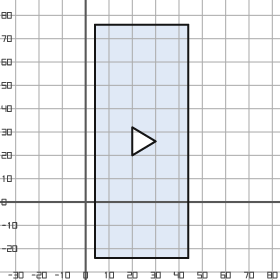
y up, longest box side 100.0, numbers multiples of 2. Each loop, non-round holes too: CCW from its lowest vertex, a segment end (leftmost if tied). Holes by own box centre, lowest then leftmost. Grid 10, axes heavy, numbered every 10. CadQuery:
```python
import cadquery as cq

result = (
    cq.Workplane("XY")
    .moveTo(4.0, -24.0)
    .lineTo(44.0, -24.0)
    .lineTo(44.0, 76.0)
    .lineTo(4.0, 76.0)
    .close()
    .moveTo(20.0, 20.0)
    .lineTo(30.0, 26.0)
    .lineTo(20.0, 32.0)
    .close()
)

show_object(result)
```